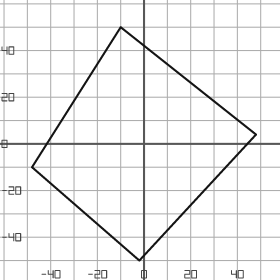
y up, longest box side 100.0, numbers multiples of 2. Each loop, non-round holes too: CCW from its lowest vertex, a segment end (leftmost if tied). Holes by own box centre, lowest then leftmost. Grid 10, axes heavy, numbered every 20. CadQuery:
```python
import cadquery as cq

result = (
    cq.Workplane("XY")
    .moveTo(-2.0, -50.0)
    .lineTo(48.0, 4.0)
    .lineTo(-10.0, 50.0)
    .lineTo(-48.0, -10.0)
    .close()
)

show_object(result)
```